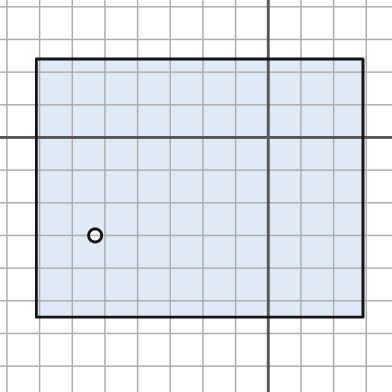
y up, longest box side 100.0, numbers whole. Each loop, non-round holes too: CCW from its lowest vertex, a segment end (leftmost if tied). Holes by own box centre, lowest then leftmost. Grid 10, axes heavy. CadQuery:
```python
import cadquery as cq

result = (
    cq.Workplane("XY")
    .moveTo(-71.0, -55.0)
    .lineTo(29.0, -55.0)
    .lineTo(29.0, 24.0)
    .lineTo(-71.0, 24.0)
    .close()
    .moveTo(-53.0, -30.0)
    .circle(2.0)
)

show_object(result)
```